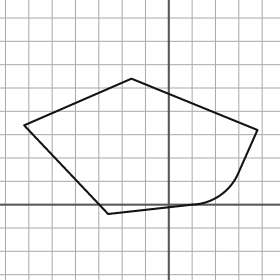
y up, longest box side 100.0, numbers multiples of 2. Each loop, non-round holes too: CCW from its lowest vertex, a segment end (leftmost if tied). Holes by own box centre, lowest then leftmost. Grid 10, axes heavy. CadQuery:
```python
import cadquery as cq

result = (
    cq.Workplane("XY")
    .moveTo(-26.0, -4.0)
    .lineTo(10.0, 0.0)
    .threePointArc((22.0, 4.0), (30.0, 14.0))
    .lineTo(38.0, 32.0)
    .lineTo(-16.0, 54.0)
    .lineTo(-62.0, 34.0)
    .close()
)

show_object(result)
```